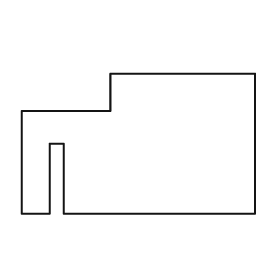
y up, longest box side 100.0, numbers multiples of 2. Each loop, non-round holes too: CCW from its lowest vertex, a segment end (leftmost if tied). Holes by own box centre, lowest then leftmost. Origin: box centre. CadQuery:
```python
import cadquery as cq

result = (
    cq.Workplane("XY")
    .moveTo(-50.0, -30.0)
    .lineTo(-38.0, -30.0)
    .lineTo(-38.0, 0.0)
    .lineTo(-32.0, 0.0)
    .lineTo(-32.0, -30.0)
    .lineTo(50.0, -30.0)
    .lineTo(50.0, 30.0)
    .lineTo(-12.0, 30.0)
    .lineTo(-12.0, 14.0)
    .lineTo(-50.0, 14.0)
    .close()
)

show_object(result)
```